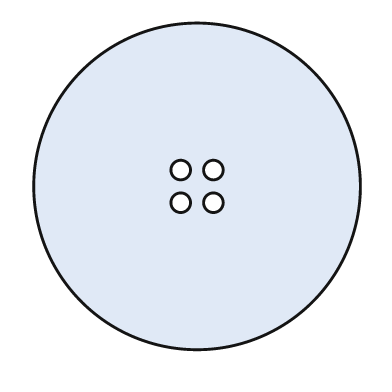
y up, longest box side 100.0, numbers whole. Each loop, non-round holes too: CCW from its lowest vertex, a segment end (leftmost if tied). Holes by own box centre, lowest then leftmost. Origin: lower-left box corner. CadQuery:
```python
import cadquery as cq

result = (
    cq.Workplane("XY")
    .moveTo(50.0, 50.0)
    .circle(50.0)
    .moveTo(45.0, 45.0)
    .circle(3.0)
    .moveTo(55.0, 45.0)
    .circle(3.0)
    .moveTo(45.0, 55.0)
    .circle(3.0)
    .moveTo(55.0, 55.0)
    .circle(3.0)
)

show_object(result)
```